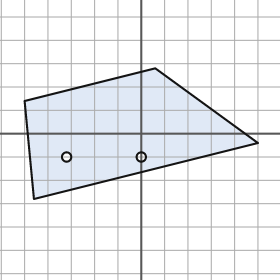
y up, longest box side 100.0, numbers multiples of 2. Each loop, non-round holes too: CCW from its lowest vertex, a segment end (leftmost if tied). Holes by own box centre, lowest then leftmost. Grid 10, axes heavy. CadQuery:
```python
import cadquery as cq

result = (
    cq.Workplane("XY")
    .moveTo(-46.0, -28.0)
    .lineTo(50.0, -4.0)
    .lineTo(6.0, 28.0)
    .lineTo(-50.0, 14.0)
    .close()
    .moveTo(-32.0, -10.0)
    .circle(2.0)
    .moveTo(0.0, -10.0)
    .circle(2.0)
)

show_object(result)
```